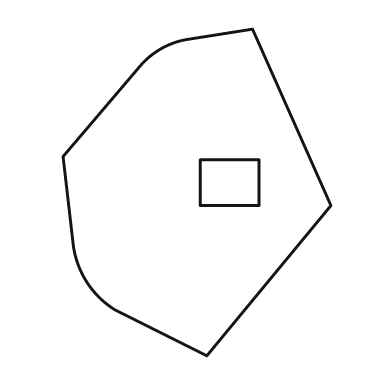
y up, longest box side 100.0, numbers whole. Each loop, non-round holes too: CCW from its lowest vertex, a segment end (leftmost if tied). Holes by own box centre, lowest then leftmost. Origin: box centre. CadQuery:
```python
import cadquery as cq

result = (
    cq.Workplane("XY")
    .moveTo(3.0, -50.0)
    .lineTo(41.0, -4.0)
    .lineTo(17.0, 50.0)
    .lineTo(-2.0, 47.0)
    .threePointArc((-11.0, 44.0), (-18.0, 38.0))
    .lineTo(-41.0, 11.0)
    .lineTo(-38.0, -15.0)
    .threePointArc((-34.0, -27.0), (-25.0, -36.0))
    .close()
    .moveTo(1.0, -4.0)
    .lineTo(19.0, -4.0)
    .lineTo(19.0, 10.0)
    .lineTo(1.0, 10.0)
    .close()
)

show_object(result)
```